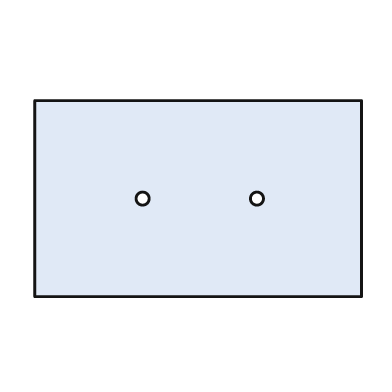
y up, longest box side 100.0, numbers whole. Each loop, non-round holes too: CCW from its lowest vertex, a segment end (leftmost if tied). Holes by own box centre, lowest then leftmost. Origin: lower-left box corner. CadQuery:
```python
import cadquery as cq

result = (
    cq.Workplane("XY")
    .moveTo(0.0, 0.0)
    .lineTo(100.0, 0.0)
    .lineTo(100.0, 60.0)
    .lineTo(0.0, 60.0)
    .close()
    .moveTo(33.0, 30.0)
    .circle(2.0)
    .moveTo(68.0, 30.0)
    .circle(2.0)
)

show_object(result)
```